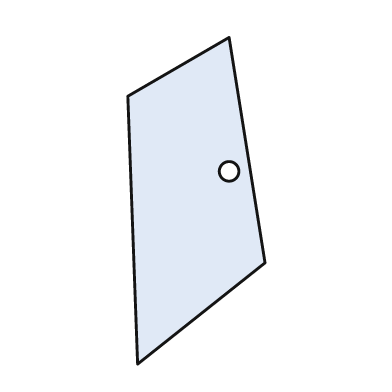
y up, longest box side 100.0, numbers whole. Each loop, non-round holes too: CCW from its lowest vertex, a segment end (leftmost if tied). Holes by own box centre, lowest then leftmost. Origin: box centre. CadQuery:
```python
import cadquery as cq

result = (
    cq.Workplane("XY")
    .moveTo(-18.0, -50.0)
    .lineTo(21.0, -19.0)
    .lineTo(10.0, 50.0)
    .lineTo(-21.0, 32.0)
    .close()
    .moveTo(10.0, 9.0)
    .circle(3.0)
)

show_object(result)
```